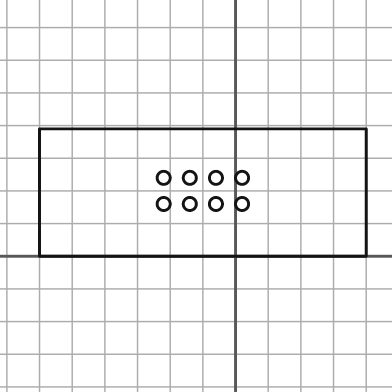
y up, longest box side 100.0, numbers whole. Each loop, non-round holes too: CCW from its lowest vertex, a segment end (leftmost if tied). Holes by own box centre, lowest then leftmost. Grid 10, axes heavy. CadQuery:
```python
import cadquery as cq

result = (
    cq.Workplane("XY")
    .moveTo(-60.0, 0.0)
    .lineTo(40.0, 0.0)
    .lineTo(40.0, 39.0)
    .lineTo(-60.0, 39.0)
    .close()
    .moveTo(-22.0, 16.0)
    .circle(2.0)
    .moveTo(-14.0, 16.0)
    .circle(2.0)
    .moveTo(-6.0, 16.0)
    .circle(2.0)
    .moveTo(2.0, 16.0)
    .circle(2.0)
    .moveTo(-22.0, 24.0)
    .circle(2.0)
    .moveTo(-14.0, 24.0)
    .circle(2.0)
    .moveTo(-6.0, 24.0)
    .circle(2.0)
    .moveTo(2.0, 24.0)
    .circle(2.0)
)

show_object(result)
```